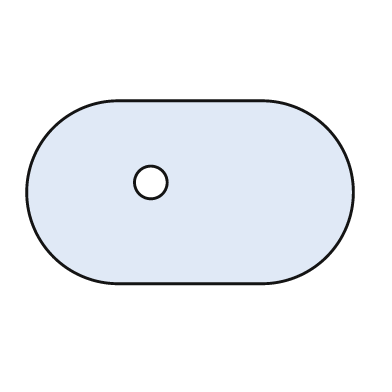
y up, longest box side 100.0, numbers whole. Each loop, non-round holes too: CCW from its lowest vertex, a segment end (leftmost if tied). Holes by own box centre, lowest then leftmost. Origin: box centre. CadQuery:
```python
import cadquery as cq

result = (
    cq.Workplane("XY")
    .moveTo(-22.0, -28.0)
    .lineTo(22.0, -28.0)
    .threePointArc((50.0, 0.0), (22.0, 28.0))
    .lineTo(-22.0, 28.0)
    .threePointArc((-50.0, 0.0), (-22.0, -28.0))
    .close()
    .moveTo(-12.0, 3.0)
    .circle(5.0)
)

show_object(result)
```